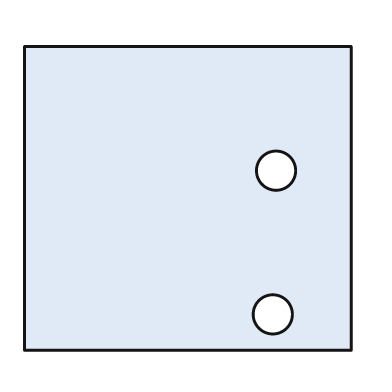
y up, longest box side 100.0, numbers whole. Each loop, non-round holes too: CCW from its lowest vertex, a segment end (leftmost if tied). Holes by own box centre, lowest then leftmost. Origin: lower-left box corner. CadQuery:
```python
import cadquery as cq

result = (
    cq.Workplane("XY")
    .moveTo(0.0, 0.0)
    .lineTo(100.0, 0.0)
    .lineTo(100.0, 93.0)
    .lineTo(0.0, 93.0)
    .close()
    .moveTo(76.0, 11.0)
    .circle(6.0)
    .moveTo(77.0, 55.0)
    .circle(6.0)
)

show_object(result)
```